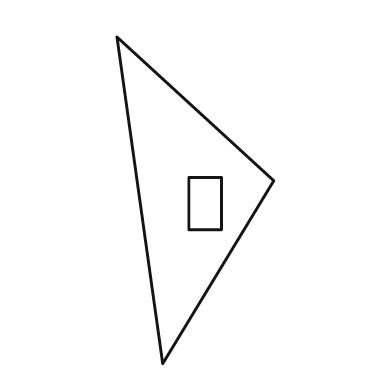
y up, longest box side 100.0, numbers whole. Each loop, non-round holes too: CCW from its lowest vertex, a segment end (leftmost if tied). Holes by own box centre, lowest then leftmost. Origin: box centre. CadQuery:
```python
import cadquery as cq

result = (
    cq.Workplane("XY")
    .moveTo(-10.0, -50.0)
    .lineTo(24.0, 6.0)
    .lineTo(-24.0, 50.0)
    .close()
    .moveTo(-2.0, -9.0)
    .lineTo(8.0, -9.0)
    .lineTo(8.0, 7.0)
    .lineTo(-2.0, 7.0)
    .close()
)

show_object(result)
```